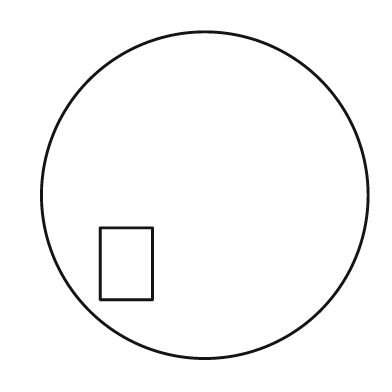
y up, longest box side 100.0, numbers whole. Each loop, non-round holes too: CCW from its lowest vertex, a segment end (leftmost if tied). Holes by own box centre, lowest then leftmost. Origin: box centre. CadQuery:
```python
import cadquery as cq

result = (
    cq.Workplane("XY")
    .moveTo(0.0, 0.0)
    .circle(50.0)
    .moveTo(-32.0, -32.0)
    .lineTo(-16.0, -32.0)
    .lineTo(-16.0, -10.0)
    .lineTo(-32.0, -10.0)
    .close()
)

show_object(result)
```